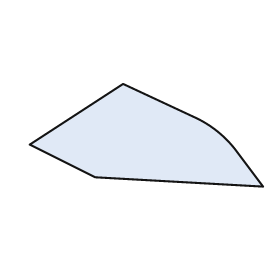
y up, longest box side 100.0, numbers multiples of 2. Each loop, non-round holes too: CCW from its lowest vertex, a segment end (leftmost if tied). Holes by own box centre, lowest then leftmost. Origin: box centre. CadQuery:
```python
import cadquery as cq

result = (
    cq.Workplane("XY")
    .moveTo(50.0, -22.0)
    .lineTo(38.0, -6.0)
    .threePointArc((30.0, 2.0), (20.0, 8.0))
    .lineTo(-10.0, 22.0)
    .lineTo(-50.0, -4.0)
    .lineTo(-22.0, -18.0)
    .close()
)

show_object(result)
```